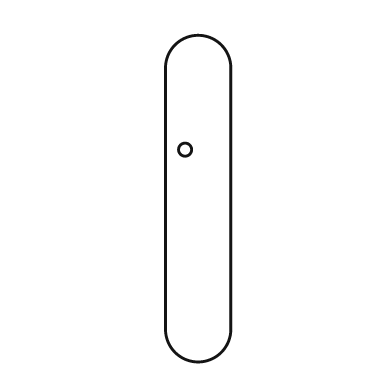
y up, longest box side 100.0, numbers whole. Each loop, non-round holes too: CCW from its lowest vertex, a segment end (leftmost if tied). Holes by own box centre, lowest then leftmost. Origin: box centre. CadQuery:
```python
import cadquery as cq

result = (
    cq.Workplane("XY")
    .moveTo(-10.0, -40.0)
    .threePointArc((0.0, -50.0), (10.0, -40.0))
    .lineTo(10.0, 40.0)
    .threePointArc((0.0, 50.0), (-10.0, 40.0))
    .close()
    .moveTo(-4.0, 15.0)
    .circle(2.0)
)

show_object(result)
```